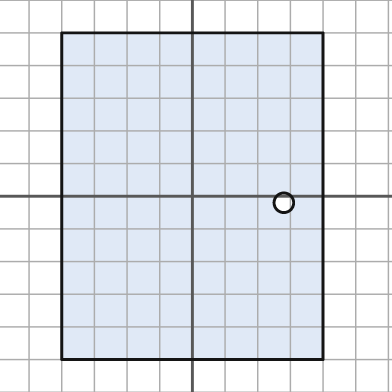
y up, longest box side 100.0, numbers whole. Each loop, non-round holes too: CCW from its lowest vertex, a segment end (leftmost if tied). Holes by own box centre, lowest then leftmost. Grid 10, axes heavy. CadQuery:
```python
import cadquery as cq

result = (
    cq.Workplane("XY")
    .moveTo(-40.0, -50.0)
    .lineTo(40.0, -50.0)
    .lineTo(40.0, 50.0)
    .lineTo(-40.0, 50.0)
    .close()
    .moveTo(28.0, -2.0)
    .circle(3.0)
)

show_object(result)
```